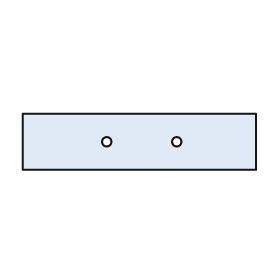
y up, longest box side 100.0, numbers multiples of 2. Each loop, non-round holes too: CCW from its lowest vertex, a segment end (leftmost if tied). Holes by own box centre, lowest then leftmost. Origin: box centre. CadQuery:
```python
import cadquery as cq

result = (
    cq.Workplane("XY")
    .moveTo(-50.0, -12.0)
    .lineTo(50.0, -12.0)
    .lineTo(50.0, 12.0)
    .lineTo(-50.0, 12.0)
    .close()
    .moveTo(-14.0, 0.0)
    .circle(2.0)
    .moveTo(16.0, 0.0)
    .circle(2.0)
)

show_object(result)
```